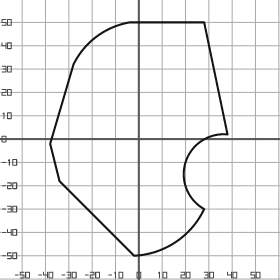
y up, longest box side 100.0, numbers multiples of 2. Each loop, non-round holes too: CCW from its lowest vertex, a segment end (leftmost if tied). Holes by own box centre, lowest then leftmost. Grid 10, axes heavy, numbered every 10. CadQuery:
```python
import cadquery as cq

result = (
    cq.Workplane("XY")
    .moveTo(-2.0, -50.0)
    .threePointArc((16.0, -44.0), (28.0, -30.0))
    .threePointArc((20.0, -10.0), (38.0, 2.0))
    .lineTo(28.0, 50.0)
    .lineTo(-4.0, 50.0)
    .threePointArc((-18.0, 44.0), (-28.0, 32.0))
    .lineTo(-38.0, -2.0)
    .lineTo(-34.0, -18.0)
    .close()
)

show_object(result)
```